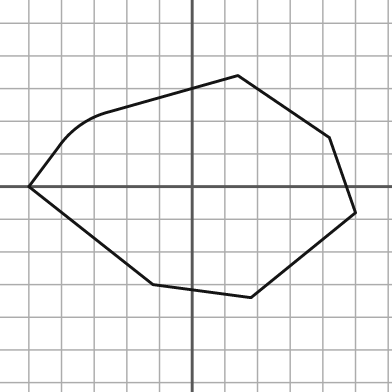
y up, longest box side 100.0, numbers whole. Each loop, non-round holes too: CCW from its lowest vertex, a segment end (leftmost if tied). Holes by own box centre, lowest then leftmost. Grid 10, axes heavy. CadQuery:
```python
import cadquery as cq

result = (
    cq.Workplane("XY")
    .moveTo(18.0, -34.0)
    .lineTo(50.0, -8.0)
    .lineTo(42.0, 15.0)
    .lineTo(14.0, 34.0)
    .lineTo(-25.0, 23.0)
    .threePointArc((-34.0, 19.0), (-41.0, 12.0))
    .lineTo(-50.0, 0.0)
    .lineTo(-12.0, -30.0)
    .close()
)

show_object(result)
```